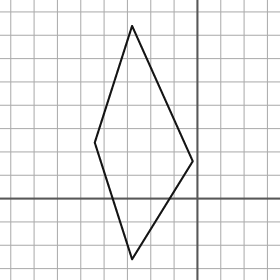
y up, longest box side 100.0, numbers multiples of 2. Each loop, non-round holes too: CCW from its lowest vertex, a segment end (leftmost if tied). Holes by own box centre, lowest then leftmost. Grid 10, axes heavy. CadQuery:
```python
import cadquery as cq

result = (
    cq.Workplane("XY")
    .moveTo(-28.0, -26.0)
    .lineTo(-2.0, 16.0)
    .lineTo(-28.0, 74.0)
    .lineTo(-44.0, 24.0)
    .close()
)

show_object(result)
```